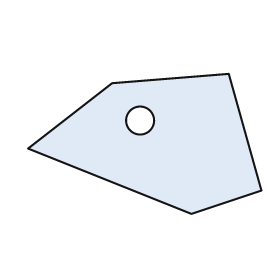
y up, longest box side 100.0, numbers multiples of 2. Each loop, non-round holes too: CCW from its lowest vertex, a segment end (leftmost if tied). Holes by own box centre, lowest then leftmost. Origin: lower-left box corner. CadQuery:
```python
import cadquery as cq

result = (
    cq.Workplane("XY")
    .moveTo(70.0, 0.0)
    .lineTo(100.0, 10.0)
    .lineTo(86.0, 60.0)
    .lineTo(36.0, 56.0)
    .lineTo(0.0, 28.0)
    .close()
    .moveTo(48.0, 40.0)
    .circle(6.0)
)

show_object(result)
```